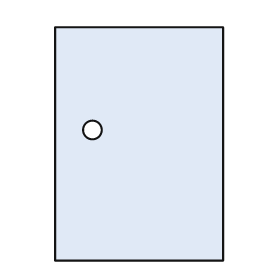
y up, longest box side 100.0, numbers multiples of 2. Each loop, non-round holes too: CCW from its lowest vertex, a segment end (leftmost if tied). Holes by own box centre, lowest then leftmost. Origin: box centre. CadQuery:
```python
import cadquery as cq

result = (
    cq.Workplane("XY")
    .moveTo(-36.0, -50.0)
    .lineTo(36.0, -50.0)
    .lineTo(36.0, 50.0)
    .lineTo(-36.0, 50.0)
    .close()
    .moveTo(-20.0, 6.0)
    .circle(4.0)
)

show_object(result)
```